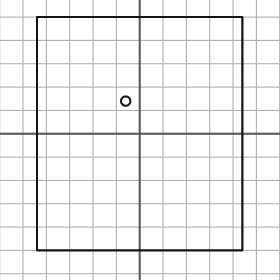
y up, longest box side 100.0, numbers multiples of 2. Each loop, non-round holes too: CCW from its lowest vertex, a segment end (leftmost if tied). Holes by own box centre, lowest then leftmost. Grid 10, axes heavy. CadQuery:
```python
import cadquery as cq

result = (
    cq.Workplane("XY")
    .moveTo(-44.0, -50.0)
    .lineTo(44.0, -50.0)
    .lineTo(44.0, 50.0)
    .lineTo(-44.0, 50.0)
    .close()
    .moveTo(-6.0, 14.0)
    .circle(2.0)
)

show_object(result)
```